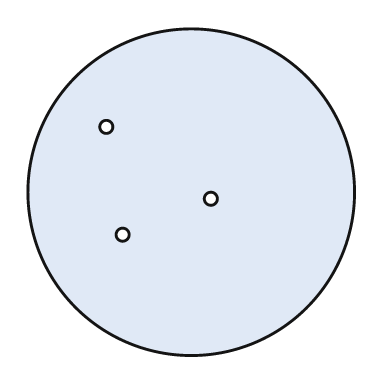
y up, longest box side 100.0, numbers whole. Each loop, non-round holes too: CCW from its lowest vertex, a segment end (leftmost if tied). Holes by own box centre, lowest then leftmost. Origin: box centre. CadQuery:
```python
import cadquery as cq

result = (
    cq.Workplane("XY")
    .moveTo(0.0, 0.0)
    .circle(50.0)
    .moveTo(-21.0, -13.0)
    .circle(2.0)
    .moveTo(6.0, -2.0)
    .circle(2.0)
    .moveTo(-26.0, 20.0)
    .circle(2.0)
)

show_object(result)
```